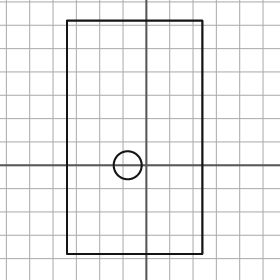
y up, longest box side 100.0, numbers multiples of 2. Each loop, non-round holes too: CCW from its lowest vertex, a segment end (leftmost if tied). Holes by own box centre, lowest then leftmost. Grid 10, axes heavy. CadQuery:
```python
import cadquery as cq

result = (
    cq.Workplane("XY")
    .moveTo(-34.0, -38.0)
    .lineTo(24.0, -38.0)
    .lineTo(24.0, 62.0)
    .lineTo(-34.0, 62.0)
    .close()
    .moveTo(-8.0, 0.0)
    .circle(6.0)
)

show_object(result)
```